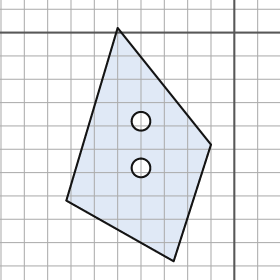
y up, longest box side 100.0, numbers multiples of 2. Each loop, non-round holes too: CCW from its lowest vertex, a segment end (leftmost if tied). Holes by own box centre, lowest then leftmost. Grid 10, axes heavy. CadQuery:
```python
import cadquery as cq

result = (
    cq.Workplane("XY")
    .moveTo(-26.0, -98.0)
    .lineTo(-10.0, -48.0)
    .lineTo(-50.0, 2.0)
    .lineTo(-72.0, -72.0)
    .close()
    .moveTo(-40.0, -58.0)
    .circle(4.0)
    .moveTo(-40.0, -38.0)
    .circle(4.0)
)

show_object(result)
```